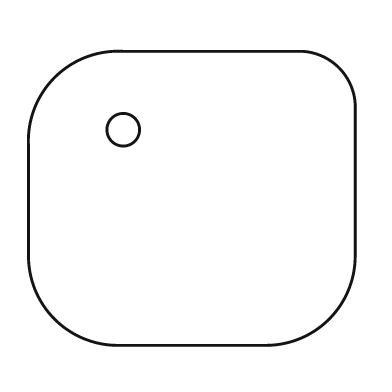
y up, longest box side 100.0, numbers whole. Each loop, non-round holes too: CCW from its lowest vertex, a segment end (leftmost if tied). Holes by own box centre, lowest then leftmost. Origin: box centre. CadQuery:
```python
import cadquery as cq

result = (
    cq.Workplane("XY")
    .moveTo(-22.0, -45.0)
    .lineTo(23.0, -45.0)
    .threePointArc((42.0, -37.0), (50.0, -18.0))
    .lineTo(50.0, 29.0)
    .threePointArc((45.0, 40.0), (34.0, 45.0))
    .lineTo(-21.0, 45.0)
    .threePointArc((-42.0, 37.0), (-50.0, 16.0))
    .lineTo(-50.0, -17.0)
    .threePointArc((-42.0, -37.0), (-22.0, -45.0))
    .close()
    .moveTo(-21.0, 21.0)
    .circle(5.0)
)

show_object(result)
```